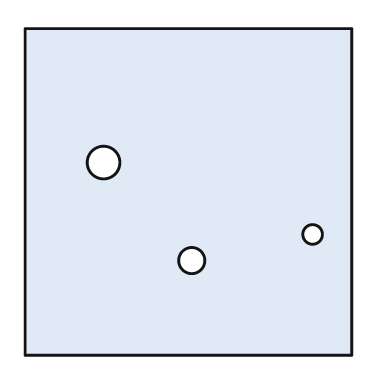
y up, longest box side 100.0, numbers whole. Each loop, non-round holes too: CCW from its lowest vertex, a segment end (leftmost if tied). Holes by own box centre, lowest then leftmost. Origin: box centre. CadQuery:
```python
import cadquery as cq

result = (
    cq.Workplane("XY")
    .moveTo(-50.0, -50.0)
    .lineTo(50.0, -50.0)
    .lineTo(50.0, 50.0)
    .lineTo(-50.0, 50.0)
    .close()
    .moveTo(1.0, -21.0)
    .circle(4.0)
    .moveTo(38.0, -13.0)
    .circle(3.0)
    .moveTo(-26.0, 9.0)
    .circle(5.0)
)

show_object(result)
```